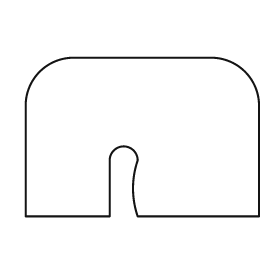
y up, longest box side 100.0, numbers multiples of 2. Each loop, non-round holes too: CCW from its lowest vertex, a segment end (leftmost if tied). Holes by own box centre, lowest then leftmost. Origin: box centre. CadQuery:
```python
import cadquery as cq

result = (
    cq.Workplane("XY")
    .moveTo(-50.0, -34.0)
    .lineTo(-14.0, -34.0)
    .lineTo(-14.0, -10.0)
    .threePointArc((-8.0, -4.0), (-2.0, -10.0))
    .threePointArc((-4.0, -22.0), (-2.0, -34.0))
    .lineTo(50.0, -34.0)
    .lineTo(50.0, 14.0)
    .threePointArc((44.0, 28.0), (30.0, 34.0))
    .lineTo(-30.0, 34.0)
    .threePointArc((-44.0, 28.0), (-50.0, 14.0))
    .close()
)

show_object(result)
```